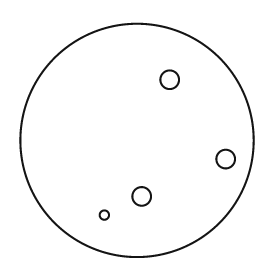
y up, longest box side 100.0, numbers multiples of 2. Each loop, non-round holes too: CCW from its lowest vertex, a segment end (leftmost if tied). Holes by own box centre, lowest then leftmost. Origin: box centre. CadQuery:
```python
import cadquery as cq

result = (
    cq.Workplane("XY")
    .moveTo(0.0, 0.0)
    .circle(50.0)
    .moveTo(-14.0, -32.0)
    .circle(2.0)
    .moveTo(2.0, -24.0)
    .circle(4.0)
    .moveTo(38.0, -8.0)
    .circle(4.0)
    .moveTo(14.0, 26.0)
    .circle(4.0)
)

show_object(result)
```